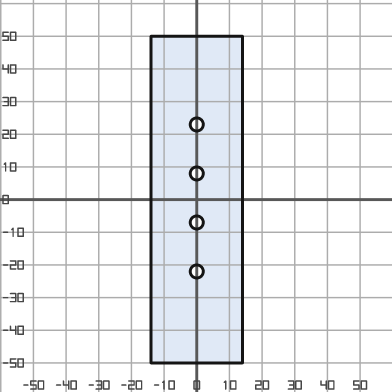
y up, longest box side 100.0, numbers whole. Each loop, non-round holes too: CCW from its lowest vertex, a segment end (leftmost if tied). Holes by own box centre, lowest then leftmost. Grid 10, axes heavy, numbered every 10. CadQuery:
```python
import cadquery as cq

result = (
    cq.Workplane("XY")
    .moveTo(-14.0, -50.0)
    .lineTo(14.0, -50.0)
    .lineTo(14.0, 50.0)
    .lineTo(-14.0, 50.0)
    .close()
    .moveTo(0.0, -22.0)
    .circle(2.0)
    .moveTo(0.0, -7.0)
    .circle(2.0)
    .moveTo(0.0, 8.0)
    .circle(2.0)
    .moveTo(0.0, 23.0)
    .circle(2.0)
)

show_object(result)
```